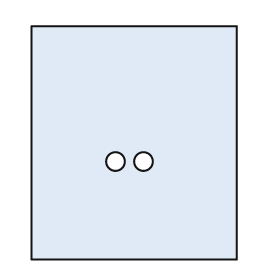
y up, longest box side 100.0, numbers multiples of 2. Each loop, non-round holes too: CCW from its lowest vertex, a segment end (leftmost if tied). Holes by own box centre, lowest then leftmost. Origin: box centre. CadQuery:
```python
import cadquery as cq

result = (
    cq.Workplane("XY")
    .moveTo(-44.0, -50.0)
    .lineTo(44.0, -50.0)
    .lineTo(44.0, 50.0)
    .lineTo(-44.0, 50.0)
    .close()
    .moveTo(-8.0, -8.0)
    .circle(4.0)
    .moveTo(4.0, -8.0)
    .circle(4.0)
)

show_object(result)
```